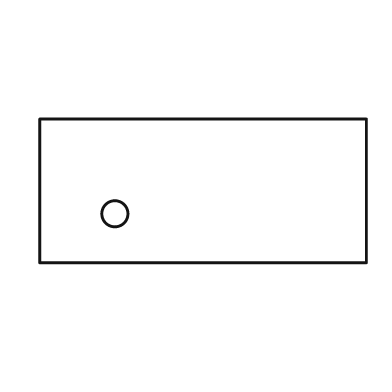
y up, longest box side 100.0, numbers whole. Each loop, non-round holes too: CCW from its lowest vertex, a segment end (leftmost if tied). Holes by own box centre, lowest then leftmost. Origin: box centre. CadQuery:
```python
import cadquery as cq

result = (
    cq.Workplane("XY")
    .moveTo(-50.0, -22.0)
    .lineTo(50.0, -22.0)
    .lineTo(50.0, 22.0)
    .lineTo(-50.0, 22.0)
    .close()
    .moveTo(-27.0, -7.0)
    .circle(4.0)
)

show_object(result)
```